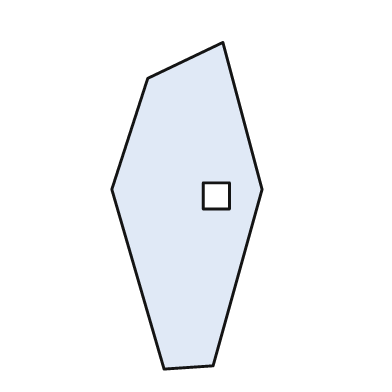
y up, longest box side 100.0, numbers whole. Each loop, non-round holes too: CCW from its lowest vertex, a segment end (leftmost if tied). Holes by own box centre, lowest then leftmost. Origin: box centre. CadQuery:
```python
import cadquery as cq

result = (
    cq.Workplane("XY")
    .moveTo(-7.0, -50.0)
    .lineTo(8.0, -49.0)
    .lineTo(23.0, 5.0)
    .lineTo(11.0, 50.0)
    .lineTo(-12.0, 39.0)
    .lineTo(-23.0, 5.0)
    .close()
    .moveTo(5.0, -1.0)
    .lineTo(13.0, -1.0)
    .lineTo(13.0, 7.0)
    .lineTo(5.0, 7.0)
    .close()
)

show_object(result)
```